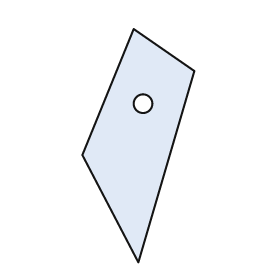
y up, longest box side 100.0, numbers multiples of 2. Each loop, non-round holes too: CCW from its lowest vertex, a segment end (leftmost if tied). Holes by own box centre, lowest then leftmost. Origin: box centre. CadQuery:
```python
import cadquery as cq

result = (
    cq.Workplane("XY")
    .moveTo(0.0, -50.0)
    .lineTo(24.0, 32.0)
    .lineTo(-2.0, 50.0)
    .lineTo(-24.0, -4.0)
    .close()
    .moveTo(2.0, 18.0)
    .circle(4.0)
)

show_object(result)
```